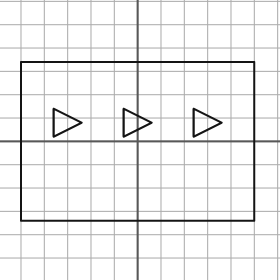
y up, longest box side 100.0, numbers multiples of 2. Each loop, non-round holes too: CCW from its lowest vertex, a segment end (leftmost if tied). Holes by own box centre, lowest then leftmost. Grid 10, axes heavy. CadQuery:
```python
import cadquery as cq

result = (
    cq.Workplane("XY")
    .moveTo(-50.0, -34.0)
    .lineTo(50.0, -34.0)
    .lineTo(50.0, 34.0)
    .lineTo(-50.0, 34.0)
    .close()
    .moveTo(-36.0, 2.0)
    .lineTo(-24.0, 8.0)
    .lineTo(-36.0, 14.0)
    .close()
    .moveTo(-6.0, 2.0)
    .lineTo(6.0, 8.0)
    .lineTo(-6.0, 14.0)
    .close()
    .moveTo(24.0, 2.0)
    .lineTo(36.0, 8.0)
    .lineTo(24.0, 14.0)
    .close()
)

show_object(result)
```